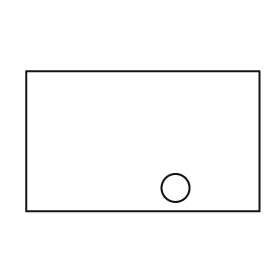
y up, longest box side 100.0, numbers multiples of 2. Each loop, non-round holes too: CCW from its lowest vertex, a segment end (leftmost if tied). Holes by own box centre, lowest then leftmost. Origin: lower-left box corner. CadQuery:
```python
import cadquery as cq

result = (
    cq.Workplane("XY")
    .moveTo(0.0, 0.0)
    .lineTo(100.0, 0.0)
    .lineTo(100.0, 60.0)
    .lineTo(0.0, 60.0)
    .close()
    .moveTo(64.0, 10.0)
    .circle(6.0)
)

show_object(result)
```